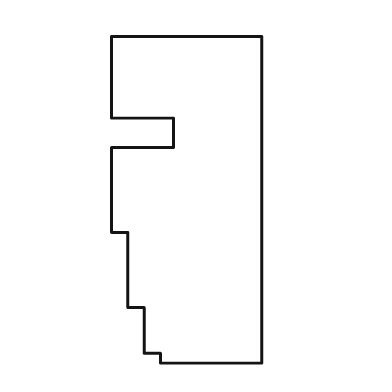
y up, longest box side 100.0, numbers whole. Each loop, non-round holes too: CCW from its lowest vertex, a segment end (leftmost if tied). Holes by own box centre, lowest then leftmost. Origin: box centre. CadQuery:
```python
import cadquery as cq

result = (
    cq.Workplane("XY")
    .moveTo(-8.0, -50.0)
    .lineTo(23.0, -50.0)
    .lineTo(23.0, 50.0)
    .lineTo(-23.0, 50.0)
    .lineTo(-23.0, 25.0)
    .lineTo(-4.0, 25.0)
    .lineTo(-4.0, 16.0)
    .lineTo(-23.0, 16.0)
    .lineTo(-23.0, -10.0)
    .lineTo(-18.0, -10.0)
    .lineTo(-18.0, -33.0)
    .lineTo(-13.0, -33.0)
    .lineTo(-13.0, -47.0)
    .lineTo(-8.0, -47.0)
    .close()
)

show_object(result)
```